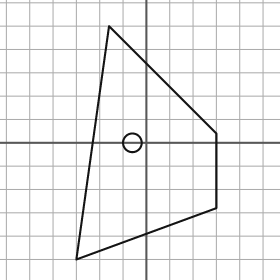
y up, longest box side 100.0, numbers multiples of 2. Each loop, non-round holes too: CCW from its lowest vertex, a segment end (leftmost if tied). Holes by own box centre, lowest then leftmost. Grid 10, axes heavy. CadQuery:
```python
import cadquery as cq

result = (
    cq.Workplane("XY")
    .moveTo(-30.0, -50.0)
    .lineTo(30.0, -28.0)
    .lineTo(30.0, 4.0)
    .lineTo(-16.0, 50.0)
    .close()
    .moveTo(-6.0, 0.0)
    .circle(4.0)
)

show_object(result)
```